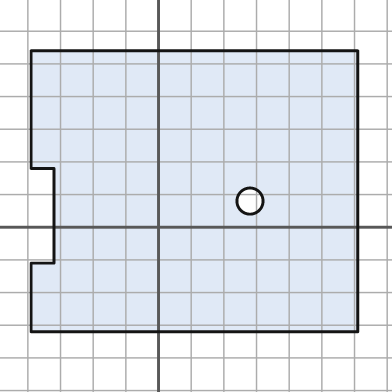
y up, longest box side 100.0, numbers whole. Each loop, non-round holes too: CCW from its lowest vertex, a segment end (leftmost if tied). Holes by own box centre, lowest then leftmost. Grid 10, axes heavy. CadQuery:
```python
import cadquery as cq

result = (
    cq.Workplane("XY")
    .moveTo(-39.0, -32.0)
    .lineTo(61.0, -32.0)
    .lineTo(61.0, 54.0)
    .lineTo(-39.0, 54.0)
    .lineTo(-39.0, 18.0)
    .lineTo(-32.0, 18.0)
    .lineTo(-32.0, -11.0)
    .lineTo(-39.0, -11.0)
    .close()
    .moveTo(28.0, 8.0)
    .circle(4.0)
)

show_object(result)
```